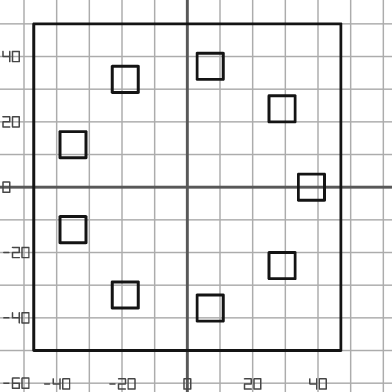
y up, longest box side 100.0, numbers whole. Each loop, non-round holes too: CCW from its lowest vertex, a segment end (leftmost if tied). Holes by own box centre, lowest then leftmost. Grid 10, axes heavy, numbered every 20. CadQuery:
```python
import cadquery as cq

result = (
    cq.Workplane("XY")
    .moveTo(-47.0, -50.0)
    .lineTo(47.0, -50.0)
    .lineTo(47.0, 50.0)
    .lineTo(-47.0, 50.0)
    .close()
    .moveTo(3.0, -41.0)
    .lineTo(11.0, -41.0)
    .lineTo(11.0, -33.0)
    .lineTo(3.0, -33.0)
    .close()
    .moveTo(-23.0, -37.0)
    .lineTo(-15.0, -37.0)
    .lineTo(-15.0, -29.0)
    .lineTo(-23.0, -29.0)
    .close()
    .moveTo(25.0, -28.0)
    .lineTo(33.0, -28.0)
    .lineTo(33.0, -20.0)
    .lineTo(25.0, -20.0)
    .close()
    .moveTo(-39.0, -17.0)
    .lineTo(-31.0, -17.0)
    .lineTo(-31.0, -9.0)
    .lineTo(-39.0, -9.0)
    .close()
    .moveTo(34.0, -4.0)
    .lineTo(42.0, -4.0)
    .lineTo(42.0, 4.0)
    .lineTo(34.0, 4.0)
    .close()
    .moveTo(-39.0, 9.0)
    .lineTo(-31.0, 9.0)
    .lineTo(-31.0, 17.0)
    .lineTo(-39.0, 17.0)
    .close()
    .moveTo(25.0, 20.0)
    .lineTo(33.0, 20.0)
    .lineTo(33.0, 28.0)
    .lineTo(25.0, 28.0)
    .close()
    .moveTo(-23.0, 29.0)
    .lineTo(-15.0, 29.0)
    .lineTo(-15.0, 37.0)
    .lineTo(-23.0, 37.0)
    .close()
    .moveTo(3.0, 33.0)
    .lineTo(11.0, 33.0)
    .lineTo(11.0, 41.0)
    .lineTo(3.0, 41.0)
    .close()
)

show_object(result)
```